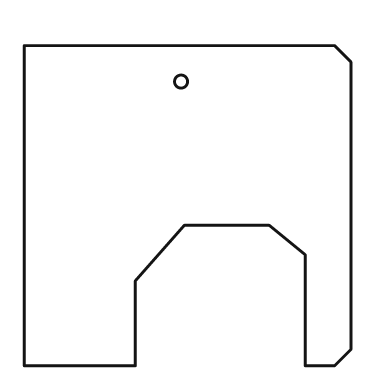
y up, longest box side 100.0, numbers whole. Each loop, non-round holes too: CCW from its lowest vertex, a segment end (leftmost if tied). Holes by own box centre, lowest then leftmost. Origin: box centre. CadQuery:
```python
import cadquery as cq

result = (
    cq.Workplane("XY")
    .moveTo(-50.0, -49.0)
    .lineTo(-16.0, -49.0)
    .lineTo(-16.0, -23.0)
    .lineTo(-1.0, -6.0)
    .lineTo(25.0, -6.0)
    .lineTo(36.0, -15.0)
    .lineTo(36.0, -49.0)
    .lineTo(45.0, -49.0)
    .lineTo(50.0, -44.0)
    .lineTo(50.0, 44.0)
    .lineTo(45.0, 49.0)
    .lineTo(-50.0, 49.0)
    .close()
    .moveTo(-2.0, 38.0)
    .circle(2.0)
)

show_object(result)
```